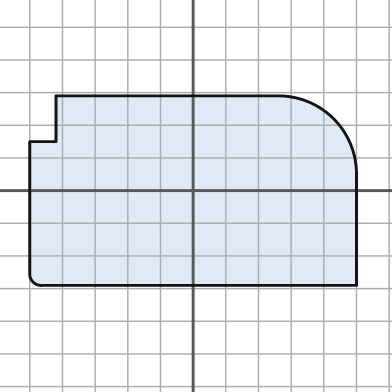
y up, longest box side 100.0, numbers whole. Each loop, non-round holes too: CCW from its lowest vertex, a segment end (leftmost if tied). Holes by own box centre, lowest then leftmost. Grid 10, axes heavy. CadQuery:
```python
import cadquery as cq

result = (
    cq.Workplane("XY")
    .moveTo(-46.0, -29.0)
    .lineTo(50.0, -29.0)
    .lineTo(50.0, 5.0)
    .threePointArc((43.0, 22.0), (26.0, 29.0))
    .lineTo(-42.0, 29.0)
    .lineTo(-42.0, 15.0)
    .lineTo(-50.0, 15.0)
    .lineTo(-50.0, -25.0)
    .threePointArc((-49.0, -28.0), (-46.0, -29.0))
    .close()
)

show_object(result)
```